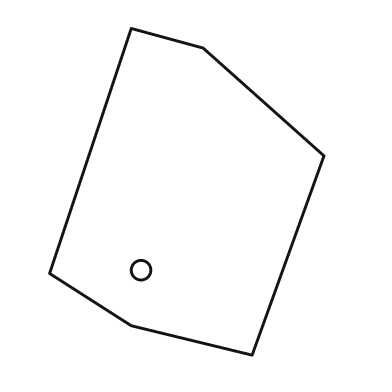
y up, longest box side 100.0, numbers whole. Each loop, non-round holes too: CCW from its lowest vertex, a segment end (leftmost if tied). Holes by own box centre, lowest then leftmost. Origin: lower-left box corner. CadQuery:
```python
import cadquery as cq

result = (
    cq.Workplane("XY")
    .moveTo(62.0, 0.0)
    .lineTo(84.0, 61.0)
    .lineTo(47.0, 94.0)
    .lineTo(25.0, 100.0)
    .lineTo(0.0, 25.0)
    .lineTo(25.0, 9.0)
    .close()
    .moveTo(28.0, 26.0)
    .circle(3.0)
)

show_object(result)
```